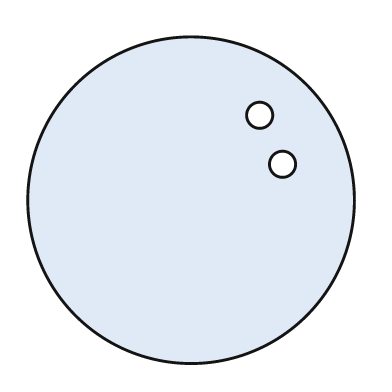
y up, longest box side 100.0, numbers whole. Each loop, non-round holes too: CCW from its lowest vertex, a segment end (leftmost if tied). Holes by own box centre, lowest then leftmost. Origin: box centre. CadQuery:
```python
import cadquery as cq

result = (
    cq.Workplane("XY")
    .moveTo(0.0, 0.0)
    .circle(50.0)
    .moveTo(28.0, 11.0)
    .circle(4.0)
    .moveTo(21.0, 26.0)
    .circle(4.0)
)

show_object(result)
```